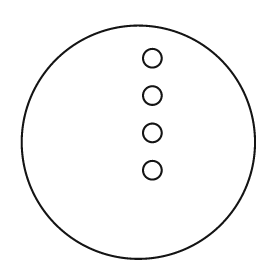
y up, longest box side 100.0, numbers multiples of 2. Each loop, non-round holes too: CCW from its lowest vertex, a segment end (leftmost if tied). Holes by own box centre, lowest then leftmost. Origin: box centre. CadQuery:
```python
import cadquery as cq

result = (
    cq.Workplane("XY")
    .moveTo(0.0, 0.0)
    .circle(50.0)
    .moveTo(6.0, -12.0)
    .circle(4.0)
    .moveTo(6.0, 4.0)
    .circle(4.0)
    .moveTo(6.0, 20.0)
    .circle(4.0)
    .moveTo(6.0, 36.0)
    .circle(4.0)
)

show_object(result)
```